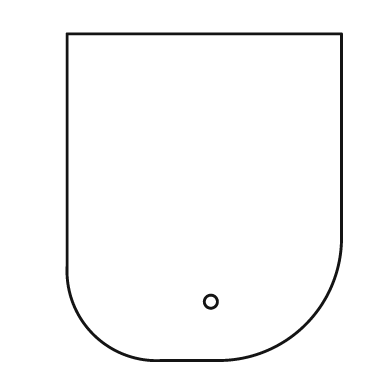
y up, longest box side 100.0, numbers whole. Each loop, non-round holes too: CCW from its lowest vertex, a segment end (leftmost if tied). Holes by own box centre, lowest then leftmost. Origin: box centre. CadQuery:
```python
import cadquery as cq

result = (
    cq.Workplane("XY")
    .moveTo(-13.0, -50.0)
    .lineTo(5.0, -50.0)
    .threePointArc((31.0, -39.0), (42.0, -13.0))
    .lineTo(42.0, 50.0)
    .lineTo(-42.0, 50.0)
    .lineTo(-42.0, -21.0)
    .threePointArc((-34.0, -42.0), (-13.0, -50.0))
    .close()
    .moveTo(2.0, -32.0)
    .circle(2.0)
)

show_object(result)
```